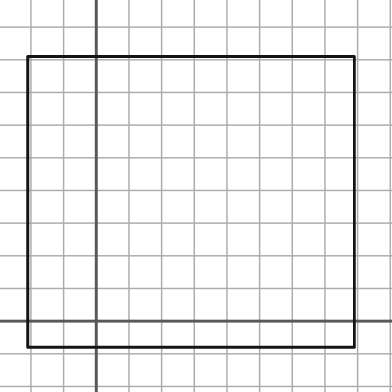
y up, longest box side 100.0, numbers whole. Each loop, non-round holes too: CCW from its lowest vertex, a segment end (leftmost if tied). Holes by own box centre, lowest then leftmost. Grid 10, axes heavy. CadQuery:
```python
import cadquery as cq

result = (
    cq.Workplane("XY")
    .moveTo(-21.0, -8.0)
    .lineTo(79.0, -8.0)
    .lineTo(79.0, 81.0)
    .lineTo(-21.0, 81.0)
    .close()
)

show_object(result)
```